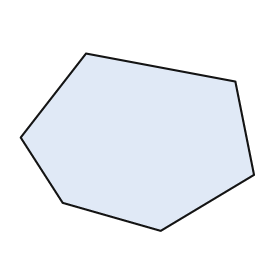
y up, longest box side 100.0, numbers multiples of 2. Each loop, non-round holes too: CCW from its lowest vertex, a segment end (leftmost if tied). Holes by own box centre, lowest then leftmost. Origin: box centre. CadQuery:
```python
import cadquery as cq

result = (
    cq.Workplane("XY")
    .moveTo(10.0, -38.0)
    .lineTo(50.0, -14.0)
    .lineTo(42.0, 26.0)
    .lineTo(-22.0, 38.0)
    .lineTo(-50.0, 2.0)
    .lineTo(-32.0, -26.0)
    .close()
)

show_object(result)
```